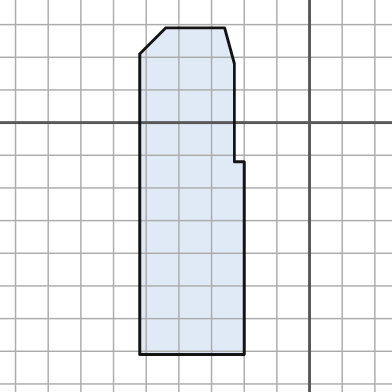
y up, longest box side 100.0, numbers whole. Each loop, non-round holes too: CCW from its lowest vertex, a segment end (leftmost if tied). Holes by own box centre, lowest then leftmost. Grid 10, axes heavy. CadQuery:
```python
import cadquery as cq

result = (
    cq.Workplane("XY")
    .moveTo(-52.0, -71.0)
    .lineTo(-20.0, -71.0)
    .lineTo(-20.0, -12.0)
    .lineTo(-23.0, -12.0)
    .lineTo(-23.0, 18.0)
    .lineTo(-26.0, 29.0)
    .lineTo(-44.0, 29.0)
    .lineTo(-52.0, 21.0)
    .close()
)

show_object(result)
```